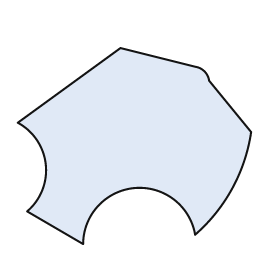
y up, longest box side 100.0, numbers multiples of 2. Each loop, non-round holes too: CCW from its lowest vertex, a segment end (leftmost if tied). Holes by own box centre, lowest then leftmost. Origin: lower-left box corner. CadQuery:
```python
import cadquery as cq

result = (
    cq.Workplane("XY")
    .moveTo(28.0, 0.0)
    .threePointArc((50.0, 24.0), (76.0, 4.0))
    .threePointArc((92.0, 24.0), (100.0, 48.0))
    .lineTo(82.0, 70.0)
    .threePointArc((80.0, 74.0), (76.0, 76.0))
    .lineTo(44.0, 84.0)
    .lineTo(0.0, 52.0)
    .threePointArc((12.0, 34.0), (4.0, 14.0))
    .close()
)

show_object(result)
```